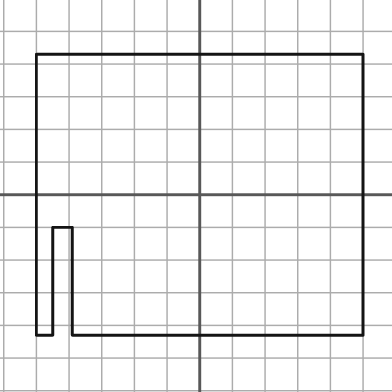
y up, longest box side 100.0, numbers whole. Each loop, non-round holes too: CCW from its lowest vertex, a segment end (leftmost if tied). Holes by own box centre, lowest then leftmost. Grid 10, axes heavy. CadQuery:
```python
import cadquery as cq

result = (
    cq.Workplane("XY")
    .moveTo(-50.0, -43.0)
    .lineTo(-45.0, -43.0)
    .lineTo(-45.0, -10.0)
    .lineTo(-39.0, -10.0)
    .lineTo(-39.0, -43.0)
    .lineTo(50.0, -43.0)
    .lineTo(50.0, 43.0)
    .lineTo(-50.0, 43.0)
    .close()
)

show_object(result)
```